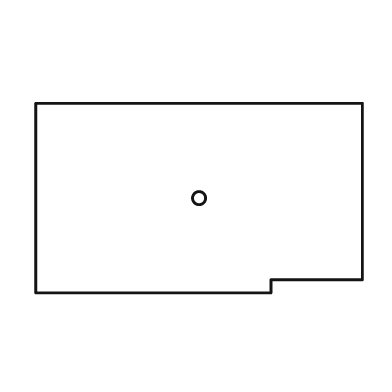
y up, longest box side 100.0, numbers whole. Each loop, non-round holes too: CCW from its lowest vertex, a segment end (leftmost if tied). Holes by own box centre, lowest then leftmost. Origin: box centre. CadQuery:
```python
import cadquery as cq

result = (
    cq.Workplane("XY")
    .moveTo(-50.0, -29.0)
    .lineTo(22.0, -29.0)
    .lineTo(22.0, -25.0)
    .lineTo(50.0, -25.0)
    .lineTo(50.0, 29.0)
    .lineTo(-50.0, 29.0)
    .close()
    .moveTo(0.0, 0.0)
    .circle(2.0)
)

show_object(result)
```